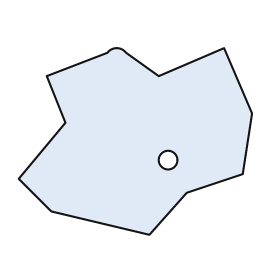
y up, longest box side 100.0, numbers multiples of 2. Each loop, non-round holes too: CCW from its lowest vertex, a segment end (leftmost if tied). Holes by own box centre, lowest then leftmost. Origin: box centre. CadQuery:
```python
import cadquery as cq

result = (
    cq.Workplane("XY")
    .moveTo(6.0, -40.0)
    .lineTo(22.0, -22.0)
    .lineTo(46.0, -14.0)
    .lineTo(50.0, 12.0)
    .lineTo(38.0, 40.0)
    .lineTo(10.0, 28.0)
    .lineTo(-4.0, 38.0)
    .threePointArc((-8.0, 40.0), (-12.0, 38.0))
    .lineTo(-38.0, 28.0)
    .lineTo(-30.0, 8.0)
    .lineTo(-50.0, -16.0)
    .lineTo(-36.0, -30.0)
    .close()
    .moveTo(14.0, -8.0)
    .circle(4.0)
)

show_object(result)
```